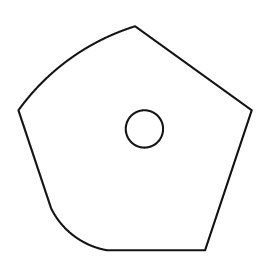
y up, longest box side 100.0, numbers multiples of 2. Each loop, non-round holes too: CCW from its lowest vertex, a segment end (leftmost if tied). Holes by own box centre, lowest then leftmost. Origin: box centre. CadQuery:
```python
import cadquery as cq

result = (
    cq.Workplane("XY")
    .moveTo(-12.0, -48.0)
    .lineTo(30.0, -48.0)
    .lineTo(50.0, 12.0)
    .lineTo(0.0, 48.0)
    .threePointArc((-28.0, 34.0), (-50.0, 12.0))
    .lineTo(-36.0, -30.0)
    .threePointArc((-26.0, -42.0), (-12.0, -48.0))
    .close()
    .moveTo(4.0, 4.0)
    .circle(8.0)
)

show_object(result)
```